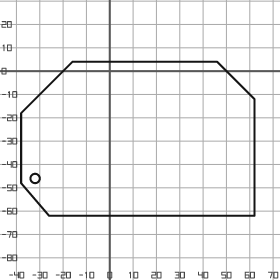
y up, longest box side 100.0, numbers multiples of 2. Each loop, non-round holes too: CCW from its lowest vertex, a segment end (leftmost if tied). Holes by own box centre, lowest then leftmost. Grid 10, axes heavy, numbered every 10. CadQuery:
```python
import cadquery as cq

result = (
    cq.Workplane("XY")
    .moveTo(-26.0, -62.0)
    .lineTo(62.0, -62.0)
    .lineTo(62.0, -12.0)
    .lineTo(46.0, 4.0)
    .lineTo(-16.0, 4.0)
    .lineTo(-38.0, -18.0)
    .lineTo(-38.0, -48.0)
    .close()
    .moveTo(-32.0, -46.0)
    .circle(2.0)
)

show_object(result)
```